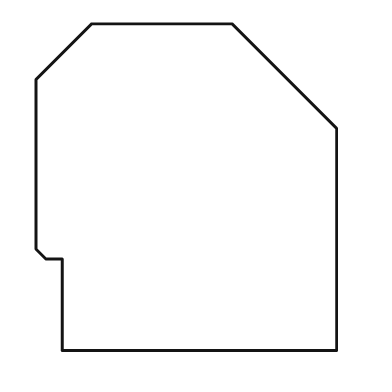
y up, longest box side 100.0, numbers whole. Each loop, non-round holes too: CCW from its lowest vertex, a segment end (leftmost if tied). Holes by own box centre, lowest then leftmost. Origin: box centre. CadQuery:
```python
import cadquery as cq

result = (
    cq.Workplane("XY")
    .moveTo(-38.0, -50.0)
    .lineTo(46.0, -50.0)
    .lineTo(46.0, 18.0)
    .lineTo(14.0, 50.0)
    .lineTo(-29.0, 50.0)
    .lineTo(-46.0, 33.0)
    .lineTo(-46.0, -19.0)
    .lineTo(-43.0, -22.0)
    .lineTo(-38.0, -22.0)
    .close()
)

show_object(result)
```